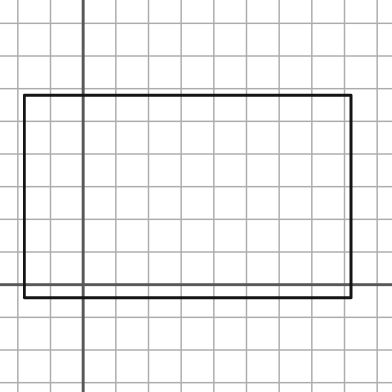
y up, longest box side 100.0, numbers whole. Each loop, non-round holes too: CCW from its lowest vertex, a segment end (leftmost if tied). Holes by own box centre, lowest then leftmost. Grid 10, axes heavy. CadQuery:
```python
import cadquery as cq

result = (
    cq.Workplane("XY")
    .moveTo(-18.0, -4.0)
    .lineTo(82.0, -4.0)
    .lineTo(82.0, 58.0)
    .lineTo(-18.0, 58.0)
    .close()
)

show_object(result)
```